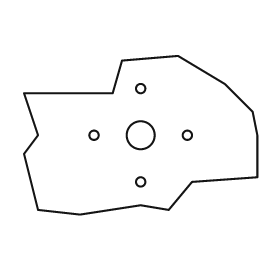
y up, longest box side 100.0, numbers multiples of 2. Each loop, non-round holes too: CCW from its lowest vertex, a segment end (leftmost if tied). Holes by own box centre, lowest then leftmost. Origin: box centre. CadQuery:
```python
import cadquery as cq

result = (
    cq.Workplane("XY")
    .moveTo(-26.0, -34.0)
    .lineTo(0.0, -30.0)
    .lineTo(12.0, -32.0)
    .lineTo(22.0, -20.0)
    .lineTo(50.0, -18.0)
    .lineTo(50.0, 0.0)
    .lineTo(48.0, 10.0)
    .lineTo(36.0, 22.0)
    .lineTo(16.0, 34.0)
    .lineTo(-8.0, 32.0)
    .lineTo(-12.0, 18.0)
    .lineTo(-50.0, 18.0)
    .lineTo(-44.0, 0.0)
    .lineTo(-50.0, -8.0)
    .lineTo(-44.0, -32.0)
    .close()
    .moveTo(0.0, -20.0)
    .circle(2.0)
    .moveTo(-20.0, 0.0)
    .circle(2.0)
    .moveTo(0.0, 0.0)
    .circle(6.0)
    .moveTo(20.0, 0.0)
    .circle(2.0)
    .moveTo(0.0, 20.0)
    .circle(2.0)
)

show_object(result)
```